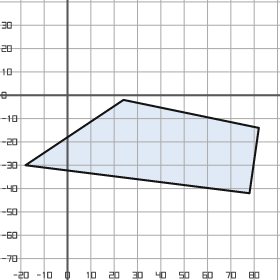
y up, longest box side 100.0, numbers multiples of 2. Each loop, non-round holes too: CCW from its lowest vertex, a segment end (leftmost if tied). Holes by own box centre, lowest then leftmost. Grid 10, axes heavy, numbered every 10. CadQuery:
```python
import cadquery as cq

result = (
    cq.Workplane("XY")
    .moveTo(78.0, -42.0)
    .lineTo(82.0, -14.0)
    .lineTo(24.0, -2.0)
    .lineTo(-18.0, -30.0)
    .close()
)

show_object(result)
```